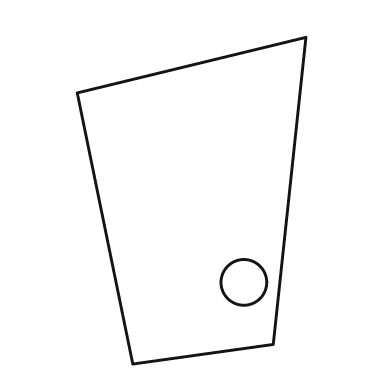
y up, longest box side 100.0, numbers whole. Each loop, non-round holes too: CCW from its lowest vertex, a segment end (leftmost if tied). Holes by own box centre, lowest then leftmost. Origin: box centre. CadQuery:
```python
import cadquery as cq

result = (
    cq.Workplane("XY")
    .moveTo(-18.0, -50.0)
    .lineTo(25.0, -44.0)
    .lineTo(35.0, 50.0)
    .lineTo(-35.0, 33.0)
    .close()
    .moveTo(16.0, -25.0)
    .circle(7.0)
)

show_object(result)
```